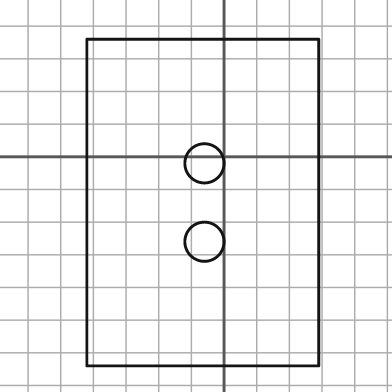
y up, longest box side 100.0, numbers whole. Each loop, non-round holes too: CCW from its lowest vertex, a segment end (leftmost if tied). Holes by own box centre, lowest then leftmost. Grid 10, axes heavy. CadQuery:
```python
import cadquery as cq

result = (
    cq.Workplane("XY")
    .moveTo(-42.0, -64.0)
    .lineTo(29.0, -64.0)
    .lineTo(29.0, 36.0)
    .lineTo(-42.0, 36.0)
    .close()
    .moveTo(-6.0, -26.0)
    .circle(6.0)
    .moveTo(-6.0, -2.0)
    .circle(6.0)
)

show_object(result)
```